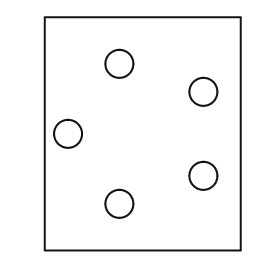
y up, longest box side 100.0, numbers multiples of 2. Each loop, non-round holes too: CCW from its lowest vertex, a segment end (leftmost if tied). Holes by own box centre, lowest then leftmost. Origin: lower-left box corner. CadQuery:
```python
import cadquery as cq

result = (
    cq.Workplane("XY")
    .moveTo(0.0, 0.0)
    .lineTo(84.0, 0.0)
    .lineTo(84.0, 100.0)
    .lineTo(0.0, 100.0)
    .close()
    .moveTo(32.0, 20.0)
    .circle(6.0)
    .moveTo(68.0, 32.0)
    .circle(6.0)
    .moveTo(10.0, 50.0)
    .circle(6.0)
    .moveTo(68.0, 68.0)
    .circle(6.0)
    .moveTo(32.0, 80.0)
    .circle(6.0)
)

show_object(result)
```